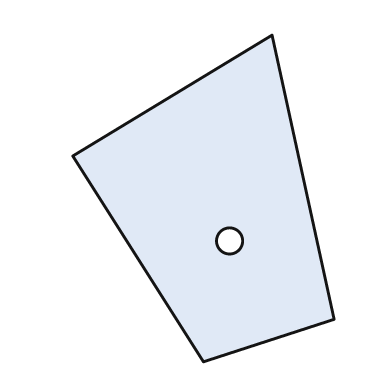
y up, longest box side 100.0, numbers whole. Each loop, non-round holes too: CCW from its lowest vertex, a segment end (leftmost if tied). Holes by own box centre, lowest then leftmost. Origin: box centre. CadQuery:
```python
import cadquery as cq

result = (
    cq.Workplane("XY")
    .moveTo(0.0, -50.0)
    .lineTo(40.0, -37.0)
    .lineTo(21.0, 50.0)
    .lineTo(-40.0, 13.0)
    .close()
    .moveTo(8.0, -13.0)
    .circle(4.0)
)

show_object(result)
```